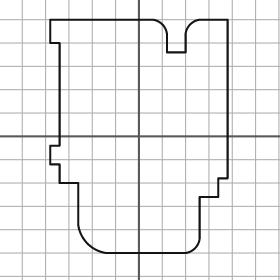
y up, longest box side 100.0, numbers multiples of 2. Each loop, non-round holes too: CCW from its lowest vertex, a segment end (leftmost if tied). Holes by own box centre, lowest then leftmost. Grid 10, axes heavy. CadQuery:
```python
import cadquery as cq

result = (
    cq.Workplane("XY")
    .moveTo(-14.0, -50.0)
    .lineTo(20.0, -50.0)
    .threePointArc((24.0, -48.0), (26.0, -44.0))
    .lineTo(26.0, -26.0)
    .lineTo(34.0, -26.0)
    .lineTo(34.0, -18.0)
    .lineTo(38.0, -18.0)
    .lineTo(38.0, 50.0)
    .lineTo(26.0, 50.0)
    .threePointArc((22.0, 48.0), (20.0, 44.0))
    .lineTo(20.0, 36.0)
    .lineTo(12.0, 36.0)
    .lineTo(12.0, 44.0)
    .threePointArc((10.0, 48.0), (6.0, 50.0))
    .lineTo(-38.0, 50.0)
    .lineTo(-38.0, 40.0)
    .lineTo(-34.0, 40.0)
    .lineTo(-34.0, -4.0)
    .lineTo(-38.0, -4.0)
    .lineTo(-38.0, -12.0)
    .lineTo(-34.0, -12.0)
    .lineTo(-34.0, -20.0)
    .lineTo(-26.0, -20.0)
    .lineTo(-26.0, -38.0)
    .threePointArc((-22.0, -46.0), (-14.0, -50.0))
    .close()
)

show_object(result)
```